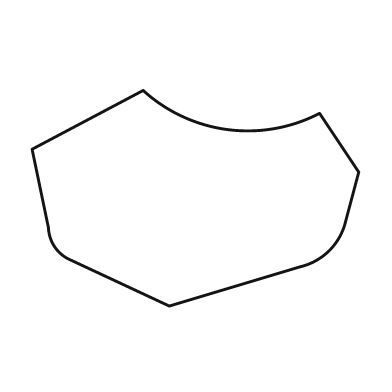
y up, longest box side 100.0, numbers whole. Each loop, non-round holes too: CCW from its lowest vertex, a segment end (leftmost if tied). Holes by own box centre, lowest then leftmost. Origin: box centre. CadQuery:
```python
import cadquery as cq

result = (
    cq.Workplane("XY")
    .moveTo(-8.0, -33.0)
    .lineTo(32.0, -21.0)
    .threePointArc((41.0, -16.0), (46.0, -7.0))
    .lineTo(50.0, 8.0)
    .lineTo(38.0, 26.0)
    .threePointArc((10.0, 21.0), (-16.0, 33.0))
    .lineTo(-50.0, 15.0)
    .lineTo(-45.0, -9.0)
    .threePointArc((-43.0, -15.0), (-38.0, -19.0))
    .close()
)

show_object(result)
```